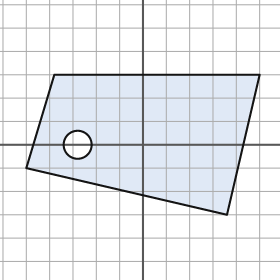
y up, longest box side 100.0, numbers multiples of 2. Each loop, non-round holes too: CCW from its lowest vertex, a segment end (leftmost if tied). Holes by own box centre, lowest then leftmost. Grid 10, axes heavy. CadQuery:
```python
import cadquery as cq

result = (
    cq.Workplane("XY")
    .moveTo(36.0, -30.0)
    .lineTo(50.0, 30.0)
    .lineTo(-38.0, 30.0)
    .lineTo(-50.0, -10.0)
    .close()
    .moveTo(-28.0, 0.0)
    .circle(6.0)
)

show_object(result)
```